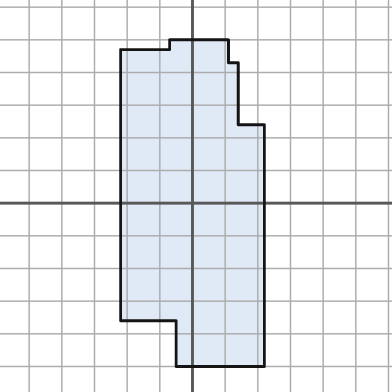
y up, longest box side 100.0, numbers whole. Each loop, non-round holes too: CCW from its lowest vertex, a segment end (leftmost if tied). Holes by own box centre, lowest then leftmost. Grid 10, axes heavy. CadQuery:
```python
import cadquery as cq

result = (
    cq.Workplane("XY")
    .moveTo(-5.0, -50.0)
    .lineTo(22.0, -50.0)
    .lineTo(22.0, 24.0)
    .lineTo(14.0, 24.0)
    .lineTo(14.0, 43.0)
    .lineTo(11.0, 43.0)
    .lineTo(11.0, 50.0)
    .lineTo(-7.0, 50.0)
    .lineTo(-7.0, 47.0)
    .lineTo(-22.0, 47.0)
    .lineTo(-22.0, -36.0)
    .lineTo(-5.0, -36.0)
    .close()
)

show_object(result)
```